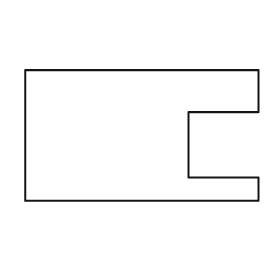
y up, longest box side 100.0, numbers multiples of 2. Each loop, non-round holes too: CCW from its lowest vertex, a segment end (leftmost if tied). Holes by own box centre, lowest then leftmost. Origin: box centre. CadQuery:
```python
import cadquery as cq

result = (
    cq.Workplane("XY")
    .moveTo(-50.0, -28.0)
    .lineTo(50.0, -28.0)
    .lineTo(50.0, -18.0)
    .lineTo(20.0, -18.0)
    .lineTo(20.0, 10.0)
    .lineTo(50.0, 10.0)
    .lineTo(50.0, 28.0)
    .lineTo(-50.0, 28.0)
    .close()
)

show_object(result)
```